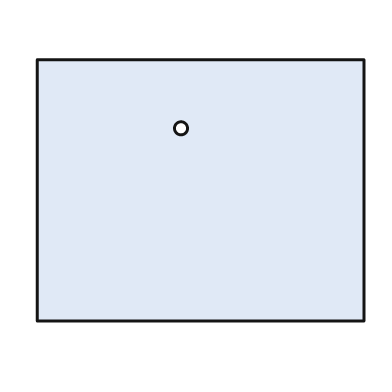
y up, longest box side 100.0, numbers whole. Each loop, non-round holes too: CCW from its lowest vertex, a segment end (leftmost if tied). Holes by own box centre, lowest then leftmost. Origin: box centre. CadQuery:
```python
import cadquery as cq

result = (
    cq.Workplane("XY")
    .moveTo(-50.0, -40.0)
    .lineTo(50.0, -40.0)
    .lineTo(50.0, 40.0)
    .lineTo(-50.0, 40.0)
    .close()
    .moveTo(-6.0, 19.0)
    .circle(2.0)
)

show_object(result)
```